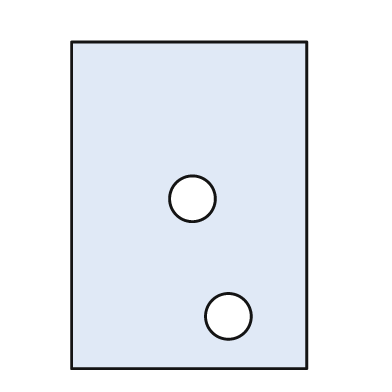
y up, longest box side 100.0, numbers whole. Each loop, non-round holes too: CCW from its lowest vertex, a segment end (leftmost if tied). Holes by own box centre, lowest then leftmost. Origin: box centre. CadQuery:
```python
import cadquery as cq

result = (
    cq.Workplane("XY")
    .moveTo(-36.0, -50.0)
    .lineTo(36.0, -50.0)
    .lineTo(36.0, 50.0)
    .lineTo(-36.0, 50.0)
    .close()
    .moveTo(12.0, -34.0)
    .circle(7.0)
    .moveTo(1.0, 2.0)
    .circle(7.0)
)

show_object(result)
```